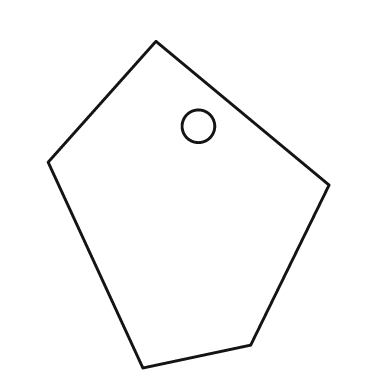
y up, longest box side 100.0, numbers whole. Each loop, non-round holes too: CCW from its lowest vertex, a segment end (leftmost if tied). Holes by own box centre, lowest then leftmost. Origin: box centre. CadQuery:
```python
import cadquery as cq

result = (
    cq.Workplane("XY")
    .moveTo(-14.0, -50.0)
    .lineTo(19.0, -43.0)
    .lineTo(43.0, 6.0)
    .lineTo(-10.0, 50.0)
    .lineTo(-43.0, 13.0)
    .close()
    .moveTo(3.0, 24.0)
    .circle(5.0)
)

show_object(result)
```